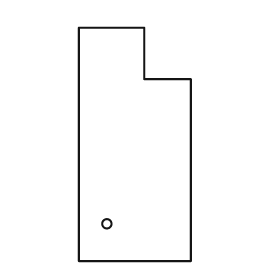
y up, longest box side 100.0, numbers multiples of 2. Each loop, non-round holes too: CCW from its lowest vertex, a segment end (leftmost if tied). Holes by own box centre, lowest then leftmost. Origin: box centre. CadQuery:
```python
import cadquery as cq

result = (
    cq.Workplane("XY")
    .moveTo(-24.0, -50.0)
    .lineTo(24.0, -50.0)
    .lineTo(24.0, 28.0)
    .lineTo(4.0, 28.0)
    .lineTo(4.0, 50.0)
    .lineTo(-24.0, 50.0)
    .close()
    .moveTo(-12.0, -34.0)
    .circle(2.0)
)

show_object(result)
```